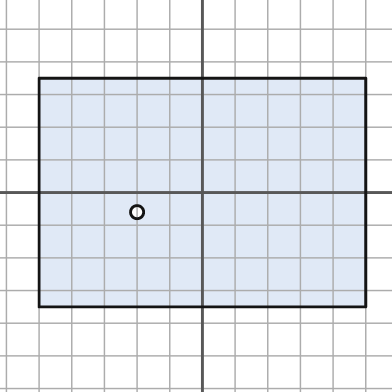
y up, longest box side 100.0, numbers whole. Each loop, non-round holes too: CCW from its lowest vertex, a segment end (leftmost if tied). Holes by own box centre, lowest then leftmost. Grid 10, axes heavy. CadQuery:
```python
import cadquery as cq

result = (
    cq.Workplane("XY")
    .moveTo(-50.0, -35.0)
    .lineTo(50.0, -35.0)
    .lineTo(50.0, 35.0)
    .lineTo(-50.0, 35.0)
    .close()
    .moveTo(-20.0, -6.0)
    .circle(2.0)
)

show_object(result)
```